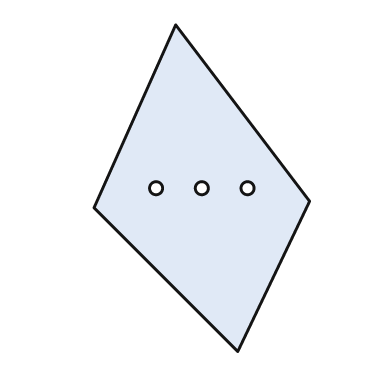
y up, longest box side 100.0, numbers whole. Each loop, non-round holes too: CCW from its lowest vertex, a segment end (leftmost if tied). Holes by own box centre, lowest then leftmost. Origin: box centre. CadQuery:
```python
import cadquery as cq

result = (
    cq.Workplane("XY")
    .moveTo(11.0, -50.0)
    .lineTo(33.0, -4.0)
    .lineTo(-8.0, 50.0)
    .lineTo(-33.0, -6.0)
    .close()
    .moveTo(-14.0, 0.0)
    .circle(2.0)
    .moveTo(0.0, 0.0)
    .circle(2.0)
    .moveTo(14.0, 0.0)
    .circle(2.0)
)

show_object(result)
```